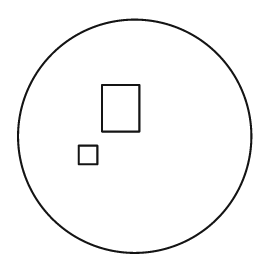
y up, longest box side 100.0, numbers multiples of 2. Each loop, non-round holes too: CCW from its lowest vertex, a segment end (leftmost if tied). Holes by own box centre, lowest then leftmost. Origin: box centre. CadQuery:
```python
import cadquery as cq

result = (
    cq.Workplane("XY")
    .moveTo(0.0, 0.0)
    .circle(50.0)
    .moveTo(-24.0, -12.0)
    .lineTo(-16.0, -12.0)
    .lineTo(-16.0, -4.0)
    .lineTo(-24.0, -4.0)
    .close()
    .moveTo(-14.0, 2.0)
    .lineTo(2.0, 2.0)
    .lineTo(2.0, 22.0)
    .lineTo(-14.0, 22.0)
    .close()
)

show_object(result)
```